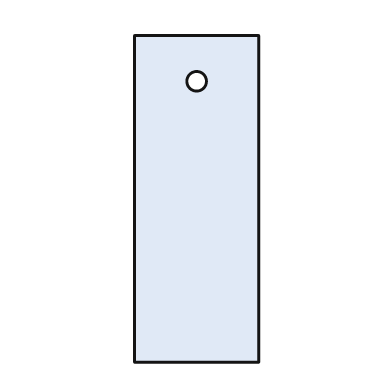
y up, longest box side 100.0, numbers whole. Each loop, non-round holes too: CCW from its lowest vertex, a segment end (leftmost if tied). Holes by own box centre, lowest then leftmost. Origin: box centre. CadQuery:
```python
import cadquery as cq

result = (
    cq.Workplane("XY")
    .moveTo(-19.0, -50.0)
    .lineTo(19.0, -50.0)
    .lineTo(19.0, 50.0)
    .lineTo(-19.0, 50.0)
    .close()
    .moveTo(0.0, 36.0)
    .circle(3.0)
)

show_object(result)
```